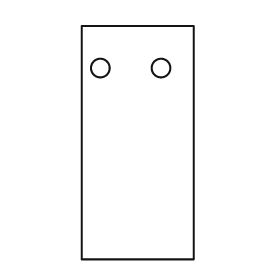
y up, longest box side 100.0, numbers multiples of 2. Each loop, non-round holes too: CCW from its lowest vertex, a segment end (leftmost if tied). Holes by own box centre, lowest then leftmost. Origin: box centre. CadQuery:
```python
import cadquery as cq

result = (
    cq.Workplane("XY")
    .moveTo(-24.0, -50.0)
    .lineTo(24.0, -50.0)
    .lineTo(24.0, 50.0)
    .lineTo(-24.0, 50.0)
    .close()
    .moveTo(-16.0, 32.0)
    .circle(4.0)
    .moveTo(10.0, 32.0)
    .circle(4.0)
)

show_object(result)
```